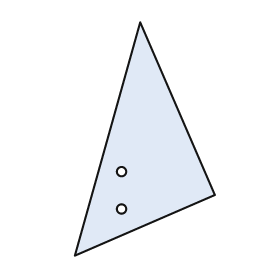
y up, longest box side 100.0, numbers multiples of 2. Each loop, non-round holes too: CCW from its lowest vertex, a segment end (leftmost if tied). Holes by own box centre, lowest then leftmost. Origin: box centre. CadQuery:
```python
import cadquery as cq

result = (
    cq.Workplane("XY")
    .moveTo(-30.0, -50.0)
    .lineTo(30.0, -24.0)
    .lineTo(-2.0, 50.0)
    .close()
    .moveTo(-10.0, -30.0)
    .circle(2.0)
    .moveTo(-10.0, -14.0)
    .circle(2.0)
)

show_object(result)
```